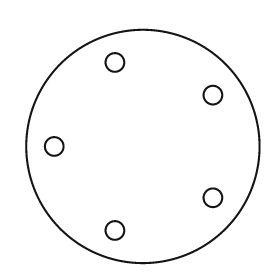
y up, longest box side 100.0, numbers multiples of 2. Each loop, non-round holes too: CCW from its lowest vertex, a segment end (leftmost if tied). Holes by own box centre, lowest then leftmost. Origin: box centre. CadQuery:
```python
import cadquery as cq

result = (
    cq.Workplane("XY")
    .moveTo(0.0, 0.0)
    .circle(50.0)
    .moveTo(-12.0, -36.0)
    .circle(4.0)
    .moveTo(30.0, -22.0)
    .circle(4.0)
    .moveTo(-38.0, 0.0)
    .circle(4.0)
    .moveTo(30.0, 22.0)
    .circle(4.0)
    .moveTo(-12.0, 36.0)
    .circle(4.0)
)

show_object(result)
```